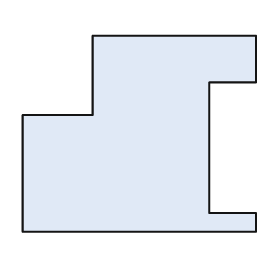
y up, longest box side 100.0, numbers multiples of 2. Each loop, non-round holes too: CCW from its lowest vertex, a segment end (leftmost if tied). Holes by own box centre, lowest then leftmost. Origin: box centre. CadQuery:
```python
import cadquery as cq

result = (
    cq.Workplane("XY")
    .moveTo(-50.0, -42.0)
    .lineTo(50.0, -42.0)
    .lineTo(50.0, -34.0)
    .lineTo(30.0, -34.0)
    .lineTo(30.0, 22.0)
    .lineTo(50.0, 22.0)
    .lineTo(50.0, 42.0)
    .lineTo(-20.0, 42.0)
    .lineTo(-20.0, 8.0)
    .lineTo(-50.0, 8.0)
    .close()
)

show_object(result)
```